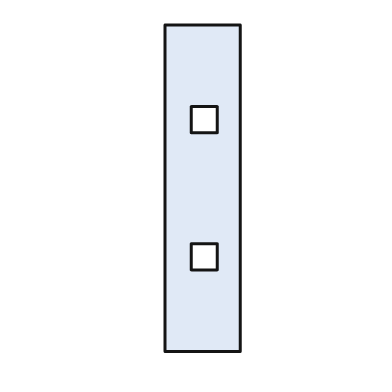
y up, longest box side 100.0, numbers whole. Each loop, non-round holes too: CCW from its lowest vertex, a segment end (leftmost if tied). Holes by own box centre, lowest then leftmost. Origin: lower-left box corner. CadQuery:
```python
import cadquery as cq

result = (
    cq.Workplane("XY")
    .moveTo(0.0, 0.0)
    .lineTo(23.0, 0.0)
    .lineTo(23.0, 100.0)
    .lineTo(0.0, 100.0)
    .close()
    .moveTo(8.0, 25.0)
    .lineTo(16.0, 25.0)
    .lineTo(16.0, 33.0)
    .lineTo(8.0, 33.0)
    .close()
    .moveTo(8.0, 67.0)
    .lineTo(16.0, 67.0)
    .lineTo(16.0, 75.0)
    .lineTo(8.0, 75.0)
    .close()
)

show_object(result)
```